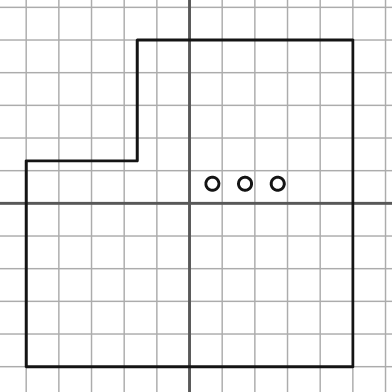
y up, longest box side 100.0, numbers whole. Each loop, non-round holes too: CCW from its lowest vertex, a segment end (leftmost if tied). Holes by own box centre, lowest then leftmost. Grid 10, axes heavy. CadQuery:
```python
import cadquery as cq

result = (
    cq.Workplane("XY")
    .moveTo(-50.0, -50.0)
    .lineTo(50.0, -50.0)
    .lineTo(50.0, 50.0)
    .lineTo(-16.0, 50.0)
    .lineTo(-16.0, 13.0)
    .lineTo(-50.0, 13.0)
    .close()
    .moveTo(7.0, 6.0)
    .circle(2.0)
    .moveTo(17.0, 6.0)
    .circle(2.0)
    .moveTo(27.0, 6.0)
    .circle(2.0)
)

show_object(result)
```